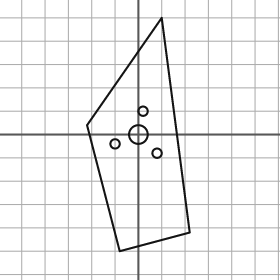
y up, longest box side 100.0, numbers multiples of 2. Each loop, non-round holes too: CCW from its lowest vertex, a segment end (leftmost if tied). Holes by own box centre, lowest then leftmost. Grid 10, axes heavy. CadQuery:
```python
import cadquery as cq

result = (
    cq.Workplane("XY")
    .moveTo(-8.0, -50.0)
    .lineTo(22.0, -42.0)
    .lineTo(10.0, 50.0)
    .lineTo(-22.0, 4.0)
    .close()
    .moveTo(8.0, -8.0)
    .circle(2.0)
    .moveTo(-10.0, -4.0)
    .circle(2.0)
    .moveTo(0.0, 0.0)
    .circle(4.0)
    .moveTo(2.0, 10.0)
    .circle(2.0)
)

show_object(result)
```